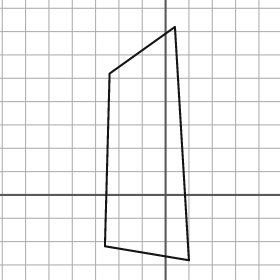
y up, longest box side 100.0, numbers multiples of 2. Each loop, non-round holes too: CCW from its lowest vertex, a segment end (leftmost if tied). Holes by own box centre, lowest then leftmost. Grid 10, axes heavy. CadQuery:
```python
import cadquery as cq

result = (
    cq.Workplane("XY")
    .moveTo(10.0, -28.0)
    .lineTo(4.0, 72.0)
    .lineTo(-24.0, 52.0)
    .lineTo(-26.0, -22.0)
    .close()
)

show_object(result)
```